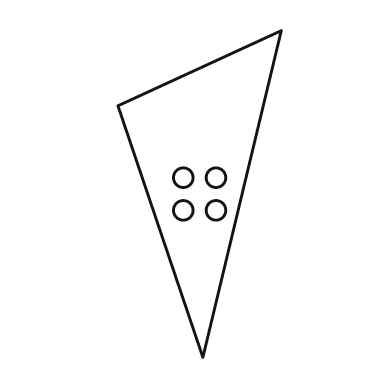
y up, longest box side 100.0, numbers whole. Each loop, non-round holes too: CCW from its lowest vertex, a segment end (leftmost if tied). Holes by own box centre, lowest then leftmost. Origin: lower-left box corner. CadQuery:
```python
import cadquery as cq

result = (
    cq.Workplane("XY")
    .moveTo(26.0, 0.0)
    .lineTo(50.0, 100.0)
    .lineTo(0.0, 77.0)
    .close()
    .moveTo(20.0, 45.0)
    .circle(3.0)
    .moveTo(30.0, 45.0)
    .circle(3.0)
    .moveTo(20.0, 55.0)
    .circle(3.0)
    .moveTo(30.0, 55.0)
    .circle(3.0)
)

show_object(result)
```